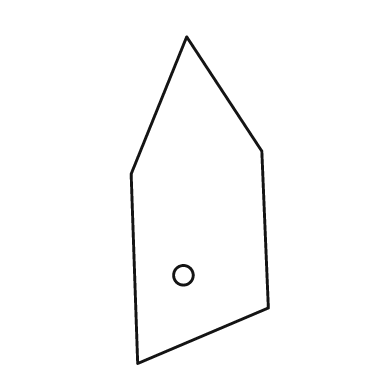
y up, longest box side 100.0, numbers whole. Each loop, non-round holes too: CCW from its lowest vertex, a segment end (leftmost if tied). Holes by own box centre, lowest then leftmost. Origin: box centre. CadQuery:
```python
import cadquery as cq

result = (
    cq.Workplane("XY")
    .moveTo(-19.0, -50.0)
    .lineTo(21.0, -33.0)
    .lineTo(19.0, 15.0)
    .lineTo(-4.0, 50.0)
    .lineTo(-21.0, 8.0)
    .close()
    .moveTo(-5.0, -23.0)
    .circle(3.0)
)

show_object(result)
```